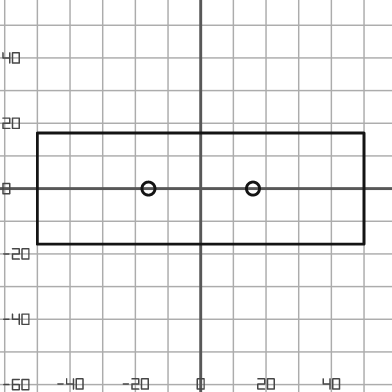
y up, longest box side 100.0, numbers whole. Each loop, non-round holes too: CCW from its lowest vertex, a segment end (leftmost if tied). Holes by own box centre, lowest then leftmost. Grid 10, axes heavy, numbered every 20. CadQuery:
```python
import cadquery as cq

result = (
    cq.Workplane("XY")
    .moveTo(-50.0, -17.0)
    .lineTo(50.0, -17.0)
    .lineTo(50.0, 17.0)
    .lineTo(-50.0, 17.0)
    .close()
    .moveTo(-16.0, 0.0)
    .circle(2.0)
    .moveTo(16.0, 0.0)
    .circle(2.0)
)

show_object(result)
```